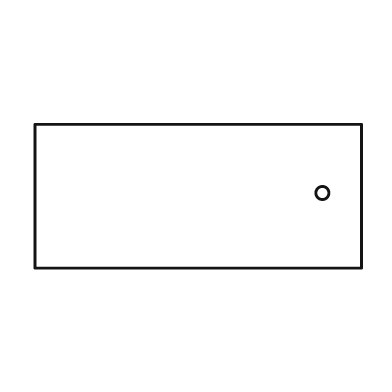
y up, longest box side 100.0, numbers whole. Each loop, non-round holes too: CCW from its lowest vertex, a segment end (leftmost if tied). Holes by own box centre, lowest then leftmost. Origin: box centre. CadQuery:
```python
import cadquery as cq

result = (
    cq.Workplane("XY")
    .moveTo(-50.0, -22.0)
    .lineTo(50.0, -22.0)
    .lineTo(50.0, 22.0)
    .lineTo(-50.0, 22.0)
    .close()
    .moveTo(38.0, 1.0)
    .circle(2.0)
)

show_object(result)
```